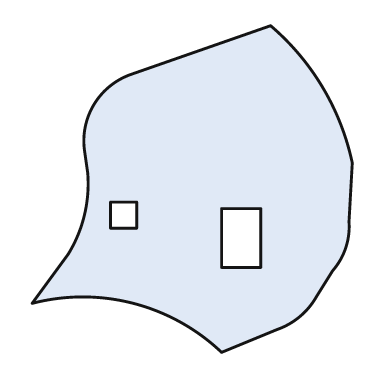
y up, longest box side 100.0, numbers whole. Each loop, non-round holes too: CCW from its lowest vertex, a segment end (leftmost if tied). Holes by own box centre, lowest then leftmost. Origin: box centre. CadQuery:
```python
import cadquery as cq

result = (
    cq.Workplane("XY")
    .moveTo(9.0, -50.0)
    .lineTo(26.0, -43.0)
    .threePointArc((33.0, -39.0), (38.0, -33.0))
    .lineTo(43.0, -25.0)
    .threePointArc((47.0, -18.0), (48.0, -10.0))
    .lineTo(49.0, 8.0)
    .threePointArc((40.0, 31.0), (24.0, 50.0))
    .lineTo(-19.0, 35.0)
    .threePointArc((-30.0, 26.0), (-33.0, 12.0))
    .lineTo(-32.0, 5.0)
    .threePointArc((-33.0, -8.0), (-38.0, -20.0))
    .lineTo(-49.0, -35.0)
    .threePointArc((-18.0, -35.0), (9.0, -50.0))
    .close()
    .moveTo(9.0, -24.0)
    .lineTo(21.0, -24.0)
    .lineTo(21.0, -6.0)
    .lineTo(9.0, -6.0)
    .close()
    .moveTo(-25.0, -12.0)
    .lineTo(-17.0, -12.0)
    .lineTo(-17.0, -4.0)
    .lineTo(-25.0, -4.0)
    .close()
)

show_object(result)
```